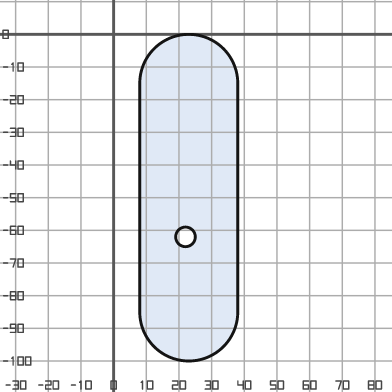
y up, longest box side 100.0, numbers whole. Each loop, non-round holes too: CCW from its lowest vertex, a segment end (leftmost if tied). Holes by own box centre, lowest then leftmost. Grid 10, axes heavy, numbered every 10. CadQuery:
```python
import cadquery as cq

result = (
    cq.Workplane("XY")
    .moveTo(8.0, -85.0)
    .threePointArc((23.0, -100.0), (38.0, -85.0))
    .lineTo(38.0, -15.0)
    .threePointArc((23.0, 0.0), (8.0, -15.0))
    .close()
    .moveTo(22.0, -62.0)
    .circle(3.0)
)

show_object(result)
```